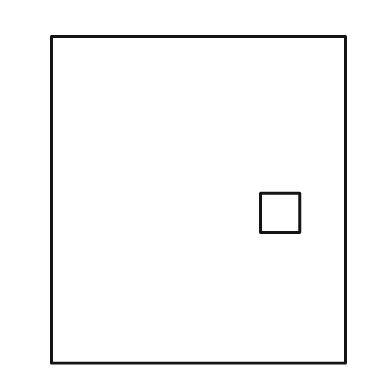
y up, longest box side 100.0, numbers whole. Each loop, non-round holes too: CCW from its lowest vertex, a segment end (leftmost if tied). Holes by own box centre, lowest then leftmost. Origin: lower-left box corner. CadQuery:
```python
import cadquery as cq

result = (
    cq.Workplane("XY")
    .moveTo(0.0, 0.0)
    .lineTo(90.0, 0.0)
    .lineTo(90.0, 100.0)
    .lineTo(0.0, 100.0)
    .close()
    .moveTo(64.0, 40.0)
    .lineTo(76.0, 40.0)
    .lineTo(76.0, 52.0)
    .lineTo(64.0, 52.0)
    .close()
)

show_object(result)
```